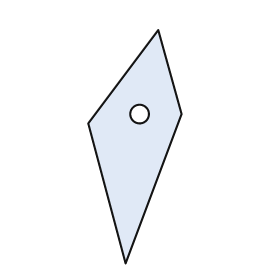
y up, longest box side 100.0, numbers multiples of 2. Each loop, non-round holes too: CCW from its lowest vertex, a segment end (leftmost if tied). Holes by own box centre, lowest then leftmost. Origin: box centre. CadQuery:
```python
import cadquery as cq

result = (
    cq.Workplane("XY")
    .moveTo(-4.0, -50.0)
    .lineTo(20.0, 14.0)
    .lineTo(10.0, 50.0)
    .lineTo(-20.0, 10.0)
    .close()
    .moveTo(2.0, 14.0)
    .circle(4.0)
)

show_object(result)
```